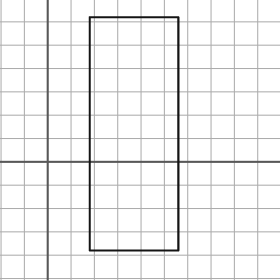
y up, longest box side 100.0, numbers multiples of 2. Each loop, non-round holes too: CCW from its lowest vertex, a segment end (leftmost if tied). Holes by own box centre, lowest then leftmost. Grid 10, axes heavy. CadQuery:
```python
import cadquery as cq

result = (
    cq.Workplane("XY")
    .moveTo(18.0, -38.0)
    .lineTo(56.0, -38.0)
    .lineTo(56.0, 62.0)
    .lineTo(18.0, 62.0)
    .close()
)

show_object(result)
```